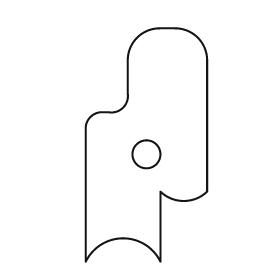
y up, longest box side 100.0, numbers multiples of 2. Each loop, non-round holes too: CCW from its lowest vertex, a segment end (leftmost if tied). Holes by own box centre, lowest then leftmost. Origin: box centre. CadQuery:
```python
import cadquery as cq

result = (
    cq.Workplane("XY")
    .moveTo(-26.0, -50.0)
    .threePointArc((-10.0, -40.0), (6.0, -50.0))
    .lineTo(6.0, -20.0)
    .threePointArc((16.0, -24.0), (26.0, -20.0))
    .lineTo(26.0, 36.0)
    .threePointArc((22.0, 46.0), (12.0, 50.0))
    .lineTo(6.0, 50.0)
    .threePointArc((-4.0, 46.0), (-8.0, 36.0))
    .lineTo(-8.0, 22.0)
    .threePointArc((-10.0, 16.0), (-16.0, 14.0))
    .lineTo(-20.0, 14.0)
    .threePointArc((-24.0, 12.0), (-26.0, 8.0))
    .close()
    .moveTo(0.0, -4.0)
    .circle(6.0)
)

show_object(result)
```